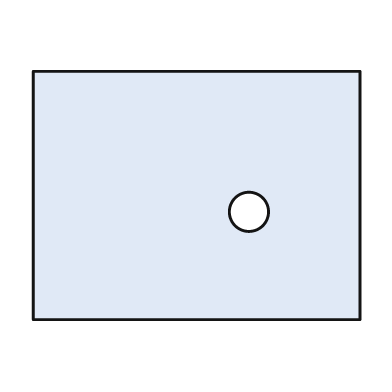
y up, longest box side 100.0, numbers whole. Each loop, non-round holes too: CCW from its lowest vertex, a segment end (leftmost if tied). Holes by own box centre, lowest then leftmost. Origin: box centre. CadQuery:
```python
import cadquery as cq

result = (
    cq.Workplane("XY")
    .moveTo(-50.0, -38.0)
    .lineTo(50.0, -38.0)
    .lineTo(50.0, 38.0)
    .lineTo(-50.0, 38.0)
    .close()
    .moveTo(16.0, -5.0)
    .circle(6.0)
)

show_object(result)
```